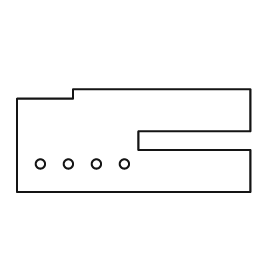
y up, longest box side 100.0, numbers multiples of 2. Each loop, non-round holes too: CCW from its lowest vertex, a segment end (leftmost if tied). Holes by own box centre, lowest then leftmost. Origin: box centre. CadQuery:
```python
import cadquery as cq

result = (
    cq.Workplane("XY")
    .moveTo(-50.0, -22.0)
    .lineTo(50.0, -22.0)
    .lineTo(50.0, -4.0)
    .lineTo(2.0, -4.0)
    .lineTo(2.0, 4.0)
    .lineTo(50.0, 4.0)
    .lineTo(50.0, 22.0)
    .lineTo(-26.0, 22.0)
    .lineTo(-26.0, 18.0)
    .lineTo(-50.0, 18.0)
    .close()
    .moveTo(-40.0, -10.0)
    .circle(2.0)
    .moveTo(-28.0, -10.0)
    .circle(2.0)
    .moveTo(-16.0, -10.0)
    .circle(2.0)
    .moveTo(-4.0, -10.0)
    .circle(2.0)
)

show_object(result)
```